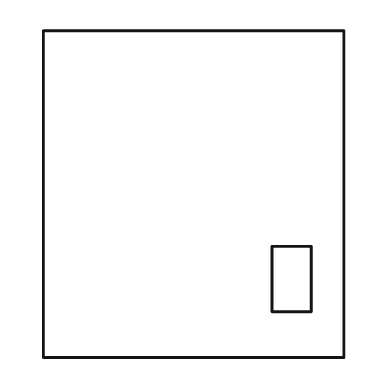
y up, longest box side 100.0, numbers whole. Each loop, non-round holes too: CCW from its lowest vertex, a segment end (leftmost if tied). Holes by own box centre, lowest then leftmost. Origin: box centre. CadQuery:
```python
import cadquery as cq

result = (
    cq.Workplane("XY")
    .moveTo(-46.0, -50.0)
    .lineTo(46.0, -50.0)
    .lineTo(46.0, 50.0)
    .lineTo(-46.0, 50.0)
    .close()
    .moveTo(24.0, -36.0)
    .lineTo(36.0, -36.0)
    .lineTo(36.0, -16.0)
    .lineTo(24.0, -16.0)
    .close()
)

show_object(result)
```